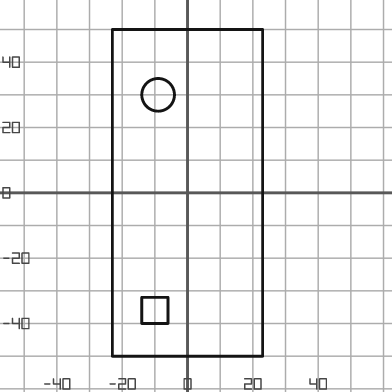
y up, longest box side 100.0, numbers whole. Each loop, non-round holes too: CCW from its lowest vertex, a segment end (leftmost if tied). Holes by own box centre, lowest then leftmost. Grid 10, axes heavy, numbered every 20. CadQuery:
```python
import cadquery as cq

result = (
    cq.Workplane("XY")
    .moveTo(-23.0, -50.0)
    .lineTo(23.0, -50.0)
    .lineTo(23.0, 50.0)
    .lineTo(-23.0, 50.0)
    .close()
    .moveTo(-14.0, -40.0)
    .lineTo(-6.0, -40.0)
    .lineTo(-6.0, -32.0)
    .lineTo(-14.0, -32.0)
    .close()
    .moveTo(-9.0, 30.0)
    .circle(5.0)
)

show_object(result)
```